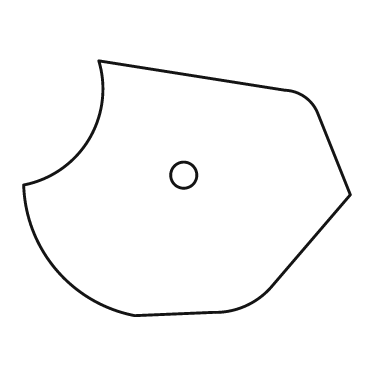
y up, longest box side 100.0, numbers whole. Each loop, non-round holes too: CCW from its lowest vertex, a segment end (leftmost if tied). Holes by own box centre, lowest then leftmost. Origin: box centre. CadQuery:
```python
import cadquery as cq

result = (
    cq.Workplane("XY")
    .moveTo(-16.0, -39.0)
    .lineTo(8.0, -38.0)
    .threePointArc((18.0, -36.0), (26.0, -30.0))
    .lineTo(50.0, -2.0)
    .lineTo(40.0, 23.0)
    .threePointArc((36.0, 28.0), (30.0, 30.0))
    .lineTo(-27.0, 39.0)
    .threePointArc((-30.0, 15.0), (-50.0, 1.0))
    .threePointArc((-40.0, -25.0), (-16.0, -39.0))
    .close()
    .moveTo(-1.0, 4.0)
    .circle(4.0)
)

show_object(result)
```